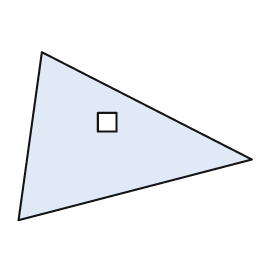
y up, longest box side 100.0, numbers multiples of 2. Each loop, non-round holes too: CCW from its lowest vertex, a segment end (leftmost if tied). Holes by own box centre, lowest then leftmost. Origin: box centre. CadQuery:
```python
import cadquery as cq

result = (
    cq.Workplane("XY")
    .moveTo(-50.0, -36.0)
    .lineTo(50.0, -10.0)
    .lineTo(-40.0, 36.0)
    .close()
    .moveTo(-16.0, 2.0)
    .lineTo(-8.0, 2.0)
    .lineTo(-8.0, 10.0)
    .lineTo(-16.0, 10.0)
    .close()
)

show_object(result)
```